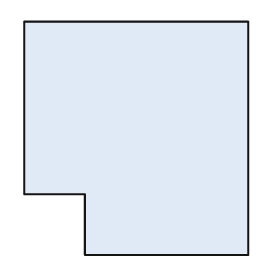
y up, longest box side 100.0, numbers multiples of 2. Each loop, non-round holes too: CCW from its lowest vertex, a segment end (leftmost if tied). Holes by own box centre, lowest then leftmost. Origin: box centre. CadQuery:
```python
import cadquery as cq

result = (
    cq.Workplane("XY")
    .moveTo(-22.0, -50.0)
    .lineTo(48.0, -50.0)
    .lineTo(48.0, 50.0)
    .lineTo(-48.0, 50.0)
    .lineTo(-48.0, -24.0)
    .lineTo(-22.0, -24.0)
    .close()
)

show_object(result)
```